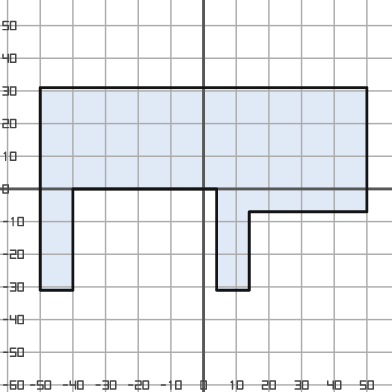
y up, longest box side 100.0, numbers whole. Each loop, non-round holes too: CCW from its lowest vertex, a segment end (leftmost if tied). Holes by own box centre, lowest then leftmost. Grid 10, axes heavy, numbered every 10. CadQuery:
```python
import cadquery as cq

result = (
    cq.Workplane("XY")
    .moveTo(-50.0, -31.0)
    .lineTo(-40.0, -31.0)
    .lineTo(-40.0, 0.0)
    .lineTo(4.0, 0.0)
    .lineTo(4.0, -31.0)
    .lineTo(14.0, -31.0)
    .lineTo(14.0, -7.0)
    .lineTo(50.0, -7.0)
    .lineTo(50.0, 31.0)
    .lineTo(-50.0, 31.0)
    .close()
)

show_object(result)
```